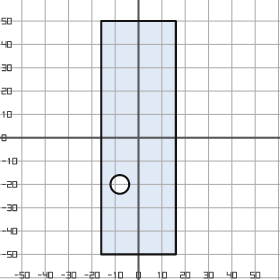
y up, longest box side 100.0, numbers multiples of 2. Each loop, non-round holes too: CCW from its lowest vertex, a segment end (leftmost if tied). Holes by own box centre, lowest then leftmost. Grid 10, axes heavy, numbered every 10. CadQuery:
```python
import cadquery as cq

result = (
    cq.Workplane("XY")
    .moveTo(-16.0, -50.0)
    .lineTo(16.0, -50.0)
    .lineTo(16.0, 50.0)
    .lineTo(-16.0, 50.0)
    .close()
    .moveTo(-8.0, -20.0)
    .circle(4.0)
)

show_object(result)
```